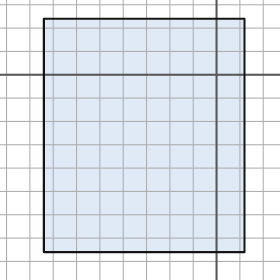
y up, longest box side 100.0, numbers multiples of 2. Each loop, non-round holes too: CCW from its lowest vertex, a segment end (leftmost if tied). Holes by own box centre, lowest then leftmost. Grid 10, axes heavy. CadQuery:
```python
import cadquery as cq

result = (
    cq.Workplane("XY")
    .moveTo(-74.0, -76.0)
    .lineTo(12.0, -76.0)
    .lineTo(12.0, 24.0)
    .lineTo(-74.0, 24.0)
    .close()
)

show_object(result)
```